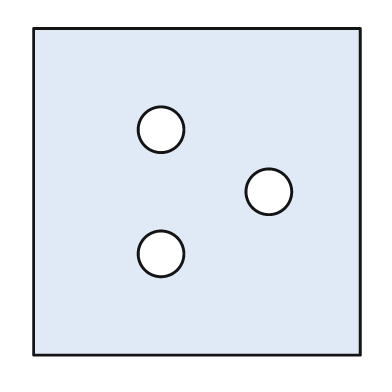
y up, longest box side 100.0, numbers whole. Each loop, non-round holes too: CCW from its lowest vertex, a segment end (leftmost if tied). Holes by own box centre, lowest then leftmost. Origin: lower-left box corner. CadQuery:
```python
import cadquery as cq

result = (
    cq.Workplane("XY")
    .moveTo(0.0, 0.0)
    .lineTo(100.0, 0.0)
    .lineTo(100.0, 100.0)
    .lineTo(0.0, 100.0)
    .close()
    .moveTo(39.0, 31.0)
    .circle(7.0)
    .moveTo(72.0, 50.0)
    .circle(7.0)
    .moveTo(39.0, 69.0)
    .circle(7.0)
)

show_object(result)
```